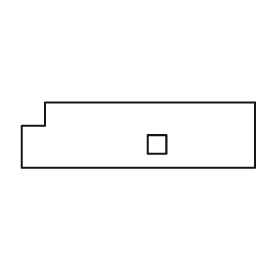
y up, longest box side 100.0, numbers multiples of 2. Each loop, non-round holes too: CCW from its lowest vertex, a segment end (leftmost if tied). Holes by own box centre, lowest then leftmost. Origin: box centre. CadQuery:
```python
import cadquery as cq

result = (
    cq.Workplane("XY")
    .moveTo(-50.0, -14.0)
    .lineTo(50.0, -14.0)
    .lineTo(50.0, 14.0)
    .lineTo(-40.0, 14.0)
    .lineTo(-40.0, 4.0)
    .lineTo(-50.0, 4.0)
    .close()
    .moveTo(4.0, -8.0)
    .lineTo(12.0, -8.0)
    .lineTo(12.0, 0.0)
    .lineTo(4.0, 0.0)
    .close()
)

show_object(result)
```